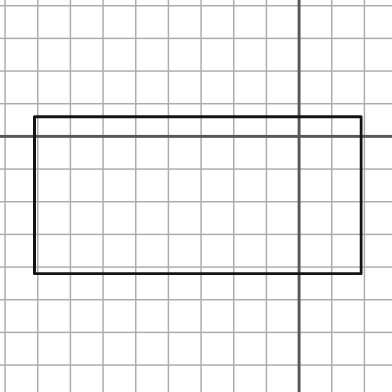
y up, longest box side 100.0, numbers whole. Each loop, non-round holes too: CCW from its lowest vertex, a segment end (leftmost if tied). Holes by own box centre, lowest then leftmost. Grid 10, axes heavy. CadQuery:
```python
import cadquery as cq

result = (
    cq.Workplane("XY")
    .moveTo(-81.0, -42.0)
    .lineTo(19.0, -42.0)
    .lineTo(19.0, 6.0)
    .lineTo(-81.0, 6.0)
    .close()
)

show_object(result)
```